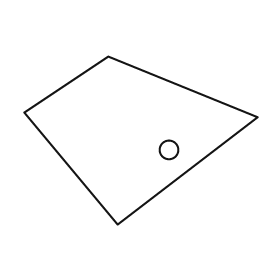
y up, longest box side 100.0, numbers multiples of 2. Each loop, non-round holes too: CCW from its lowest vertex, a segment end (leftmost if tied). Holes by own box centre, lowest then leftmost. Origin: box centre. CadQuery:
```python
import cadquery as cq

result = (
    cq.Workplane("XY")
    .moveTo(-10.0, -36.0)
    .lineTo(50.0, 10.0)
    .lineTo(-14.0, 36.0)
    .lineTo(-50.0, 12.0)
    .close()
    .moveTo(12.0, -4.0)
    .circle(4.0)
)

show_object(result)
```